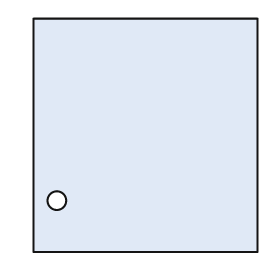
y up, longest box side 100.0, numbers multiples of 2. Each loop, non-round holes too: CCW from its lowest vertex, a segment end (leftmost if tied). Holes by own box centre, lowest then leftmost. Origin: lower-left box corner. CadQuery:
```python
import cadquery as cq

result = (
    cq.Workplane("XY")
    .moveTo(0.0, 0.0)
    .lineTo(96.0, 0.0)
    .lineTo(96.0, 100.0)
    .lineTo(0.0, 100.0)
    .close()
    .moveTo(10.0, 22.0)
    .circle(4.0)
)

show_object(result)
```